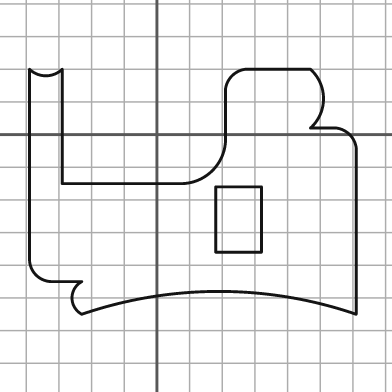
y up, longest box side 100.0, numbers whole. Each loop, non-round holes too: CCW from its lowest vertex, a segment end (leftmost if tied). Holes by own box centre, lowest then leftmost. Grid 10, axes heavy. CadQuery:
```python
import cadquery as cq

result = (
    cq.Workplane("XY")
    .moveTo(-23.0, -55.0)
    .threePointArc((19.0, -48.0), (61.0, -55.0))
    .lineTo(61.0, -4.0)
    .threePointArc((59.0, 0.0), (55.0, 2.0))
    .lineTo(47.0, 2.0)
    .threePointArc((51.0, 11.0), (47.0, 20.0))
    .lineTo(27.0, 20.0)
    .threePointArc((23.0, 18.0), (21.0, 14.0))
    .lineTo(21.0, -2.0)
    .threePointArc((17.0, -11.0), (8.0, -15.0))
    .lineTo(-29.0, -15.0)
    .lineTo(-29.0, 20.0)
    .threePointArc((-34.0, 18.0), (-39.0, 20.0))
    .lineTo(-39.0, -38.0)
    .threePointArc((-37.0, -43.0), (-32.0, -45.0))
    .lineTo(-23.0, -45.0)
    .threePointArc((-26.0, -50.0), (-23.0, -55.0))
    .close()
    .moveTo(18.0, -36.0)
    .lineTo(32.0, -36.0)
    .lineTo(32.0, -16.0)
    .lineTo(18.0, -16.0)
    .close()
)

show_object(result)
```